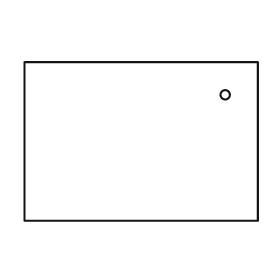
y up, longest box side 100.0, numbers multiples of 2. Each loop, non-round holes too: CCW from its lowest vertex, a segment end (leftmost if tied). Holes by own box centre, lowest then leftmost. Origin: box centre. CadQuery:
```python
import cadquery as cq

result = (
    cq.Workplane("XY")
    .moveTo(-50.0, -34.0)
    .lineTo(50.0, -34.0)
    .lineTo(50.0, 34.0)
    .lineTo(-50.0, 34.0)
    .close()
    .moveTo(36.0, 20.0)
    .circle(2.0)
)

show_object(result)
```